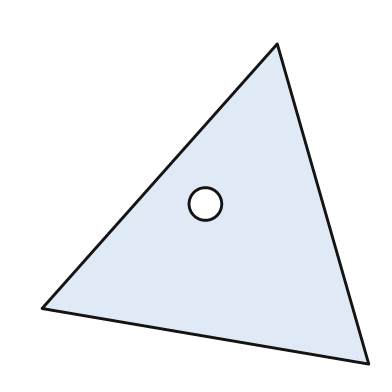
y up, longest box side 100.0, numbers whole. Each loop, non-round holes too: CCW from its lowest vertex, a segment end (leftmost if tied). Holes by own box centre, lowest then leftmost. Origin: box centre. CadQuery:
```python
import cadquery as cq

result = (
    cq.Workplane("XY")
    .moveTo(50.0, -49.0)
    .lineTo(22.0, 49.0)
    .lineTo(-50.0, -32.0)
    .close()
    .moveTo(0.0, 0.0)
    .circle(5.0)
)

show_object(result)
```